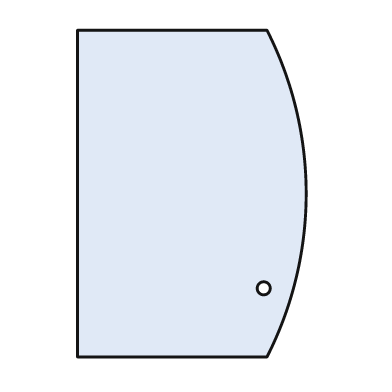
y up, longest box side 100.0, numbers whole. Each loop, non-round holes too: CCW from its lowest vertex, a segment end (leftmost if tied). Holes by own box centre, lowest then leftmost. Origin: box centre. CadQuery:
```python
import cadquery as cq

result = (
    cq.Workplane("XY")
    .moveTo(-35.0, -50.0)
    .lineTo(23.0, -50.0)
    .threePointArc((35.0, 0.0), (23.0, 50.0))
    .lineTo(-35.0, 50.0)
    .close()
    .moveTo(22.0, -29.0)
    .circle(2.0)
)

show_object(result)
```